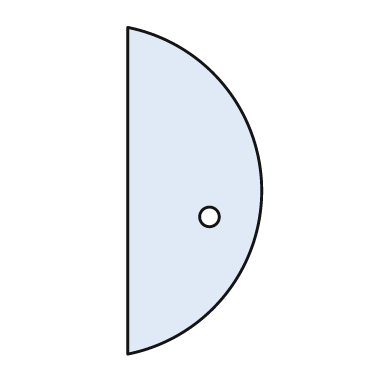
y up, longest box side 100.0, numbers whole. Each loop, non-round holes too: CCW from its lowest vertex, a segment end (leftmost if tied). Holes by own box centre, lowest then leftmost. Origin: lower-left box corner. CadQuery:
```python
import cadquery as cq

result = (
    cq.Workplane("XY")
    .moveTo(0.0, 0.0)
    .threePointArc((41.0, 50.0), (0.0, 100.0))
    .close()
    .moveTo(25.0, 42.0)
    .circle(3.0)
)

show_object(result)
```